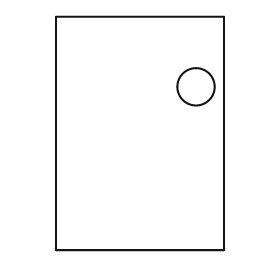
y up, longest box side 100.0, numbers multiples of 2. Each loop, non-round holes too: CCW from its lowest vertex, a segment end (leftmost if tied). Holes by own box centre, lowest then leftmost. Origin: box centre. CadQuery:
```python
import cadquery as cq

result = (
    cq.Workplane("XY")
    .moveTo(-36.0, -50.0)
    .lineTo(36.0, -50.0)
    .lineTo(36.0, 50.0)
    .lineTo(-36.0, 50.0)
    .close()
    .moveTo(24.0, 20.0)
    .circle(8.0)
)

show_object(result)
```